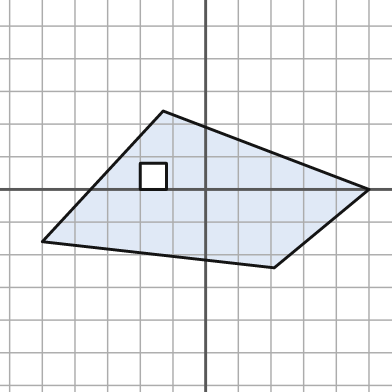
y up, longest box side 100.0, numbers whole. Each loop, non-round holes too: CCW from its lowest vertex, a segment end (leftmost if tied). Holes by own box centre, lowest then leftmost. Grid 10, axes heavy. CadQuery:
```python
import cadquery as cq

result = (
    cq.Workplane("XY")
    .moveTo(21.0, -24.0)
    .lineTo(50.0, 0.0)
    .lineTo(-13.0, 24.0)
    .lineTo(-50.0, -16.0)
    .close()
    .moveTo(-20.0, 0.0)
    .lineTo(-12.0, 0.0)
    .lineTo(-12.0, 8.0)
    .lineTo(-20.0, 8.0)
    .close()
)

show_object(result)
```